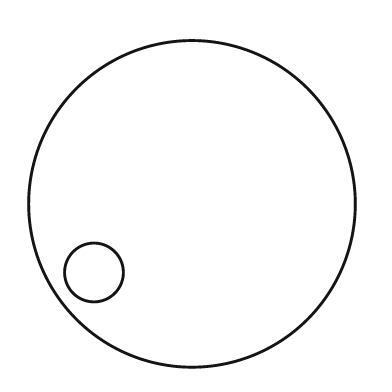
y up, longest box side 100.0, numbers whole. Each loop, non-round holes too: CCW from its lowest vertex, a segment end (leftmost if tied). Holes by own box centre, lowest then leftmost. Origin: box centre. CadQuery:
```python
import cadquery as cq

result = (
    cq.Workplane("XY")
    .moveTo(0.0, 0.0)
    .circle(50.0)
    .moveTo(-30.0, -21.0)
    .circle(9.0)
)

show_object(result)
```